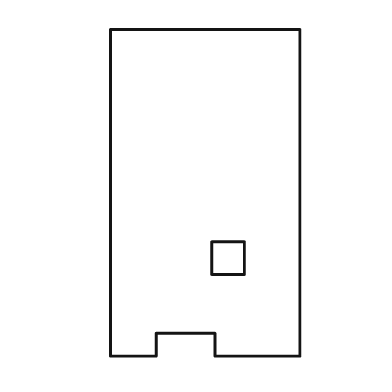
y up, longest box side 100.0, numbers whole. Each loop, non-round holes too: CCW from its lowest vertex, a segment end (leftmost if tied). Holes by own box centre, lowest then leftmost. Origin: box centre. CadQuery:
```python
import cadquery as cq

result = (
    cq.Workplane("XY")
    .moveTo(-29.0, -50.0)
    .lineTo(-15.0, -50.0)
    .lineTo(-15.0, -43.0)
    .lineTo(3.0, -43.0)
    .lineTo(3.0, -50.0)
    .lineTo(29.0, -50.0)
    .lineTo(29.0, 50.0)
    .lineTo(-29.0, 50.0)
    .close()
    .moveTo(2.0, -25.0)
    .lineTo(12.0, -25.0)
    .lineTo(12.0, -15.0)
    .lineTo(2.0, -15.0)
    .close()
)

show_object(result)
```